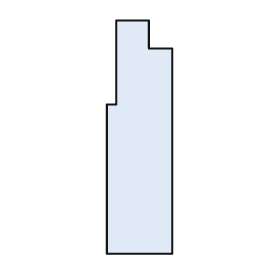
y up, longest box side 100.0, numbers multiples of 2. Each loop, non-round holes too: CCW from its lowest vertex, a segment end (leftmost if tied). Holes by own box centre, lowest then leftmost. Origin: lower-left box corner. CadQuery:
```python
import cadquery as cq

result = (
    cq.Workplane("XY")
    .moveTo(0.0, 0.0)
    .lineTo(28.0, 0.0)
    .lineTo(28.0, 88.0)
    .lineTo(18.0, 88.0)
    .lineTo(18.0, 100.0)
    .lineTo(4.0, 100.0)
    .lineTo(4.0, 64.0)
    .lineTo(0.0, 64.0)
    .close()
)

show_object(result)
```